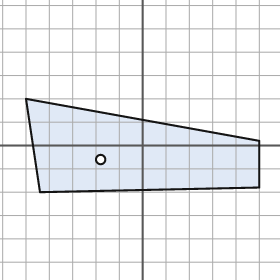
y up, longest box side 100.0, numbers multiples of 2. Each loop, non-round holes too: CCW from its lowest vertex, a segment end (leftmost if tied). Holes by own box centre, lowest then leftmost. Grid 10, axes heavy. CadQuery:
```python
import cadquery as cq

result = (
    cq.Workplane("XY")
    .moveTo(-44.0, -20.0)
    .lineTo(50.0, -18.0)
    .lineTo(50.0, 2.0)
    .lineTo(-50.0, 20.0)
    .close()
    .moveTo(-18.0, -6.0)
    .circle(2.0)
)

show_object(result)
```